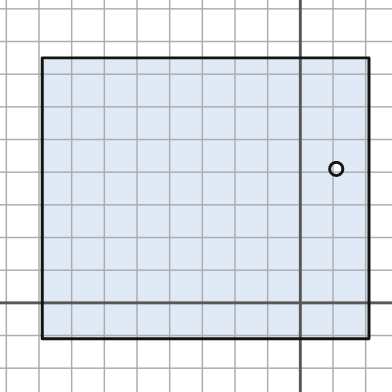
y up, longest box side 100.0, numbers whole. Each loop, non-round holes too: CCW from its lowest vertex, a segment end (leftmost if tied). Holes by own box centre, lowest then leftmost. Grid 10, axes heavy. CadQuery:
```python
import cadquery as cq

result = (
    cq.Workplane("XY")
    .moveTo(-79.0, -11.0)
    .lineTo(21.0, -11.0)
    .lineTo(21.0, 75.0)
    .lineTo(-79.0, 75.0)
    .close()
    .moveTo(11.0, 41.0)
    .circle(2.0)
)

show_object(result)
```